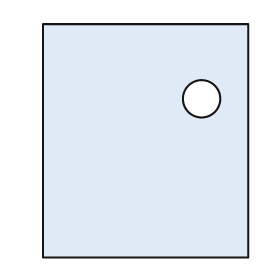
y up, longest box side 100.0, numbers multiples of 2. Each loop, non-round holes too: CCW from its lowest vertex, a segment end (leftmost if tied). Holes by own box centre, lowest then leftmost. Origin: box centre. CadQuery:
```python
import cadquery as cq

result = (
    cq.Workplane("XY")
    .moveTo(-44.0, -50.0)
    .lineTo(44.0, -50.0)
    .lineTo(44.0, 50.0)
    .lineTo(-44.0, 50.0)
    .close()
    .moveTo(24.0, 18.0)
    .circle(8.0)
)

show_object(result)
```